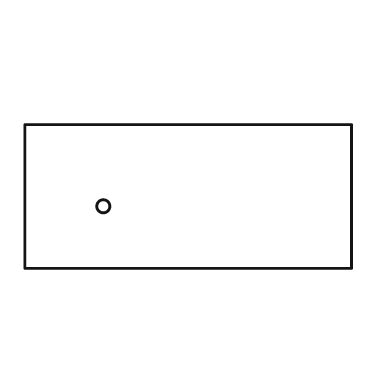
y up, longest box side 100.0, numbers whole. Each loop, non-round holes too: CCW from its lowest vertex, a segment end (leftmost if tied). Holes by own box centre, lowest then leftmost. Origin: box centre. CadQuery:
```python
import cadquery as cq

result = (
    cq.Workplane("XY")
    .moveTo(-50.0, -22.0)
    .lineTo(50.0, -22.0)
    .lineTo(50.0, 22.0)
    .lineTo(-50.0, 22.0)
    .close()
    .moveTo(-26.0, -3.0)
    .circle(2.0)
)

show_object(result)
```